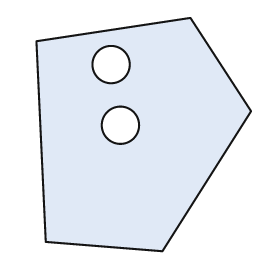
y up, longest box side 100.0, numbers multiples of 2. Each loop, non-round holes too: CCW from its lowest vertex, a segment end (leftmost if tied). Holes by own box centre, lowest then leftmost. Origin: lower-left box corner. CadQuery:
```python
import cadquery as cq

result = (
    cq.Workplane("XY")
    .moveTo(54.0, 0.0)
    .lineTo(92.0, 60.0)
    .lineTo(66.0, 100.0)
    .lineTo(0.0, 90.0)
    .lineTo(4.0, 4.0)
    .close()
    .moveTo(36.0, 54.0)
    .circle(8.0)
    .moveTo(32.0, 80.0)
    .circle(8.0)
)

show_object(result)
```